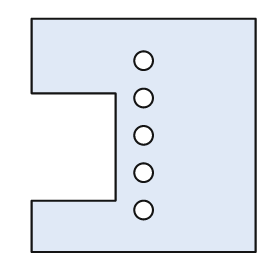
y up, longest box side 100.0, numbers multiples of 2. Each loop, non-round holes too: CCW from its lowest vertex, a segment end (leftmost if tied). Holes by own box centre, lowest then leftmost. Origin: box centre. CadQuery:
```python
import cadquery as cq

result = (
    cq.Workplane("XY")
    .moveTo(-48.0, -50.0)
    .lineTo(48.0, -50.0)
    .lineTo(48.0, 50.0)
    .lineTo(-48.0, 50.0)
    .lineTo(-48.0, 18.0)
    .lineTo(-12.0, 18.0)
    .lineTo(-12.0, -28.0)
    .lineTo(-48.0, -28.0)
    .close()
    .moveTo(0.0, -32.0)
    .circle(4.0)
    .moveTo(0.0, -16.0)
    .circle(4.0)
    .moveTo(0.0, 0.0)
    .circle(4.0)
    .moveTo(0.0, 16.0)
    .circle(4.0)
    .moveTo(0.0, 32.0)
    .circle(4.0)
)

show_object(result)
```